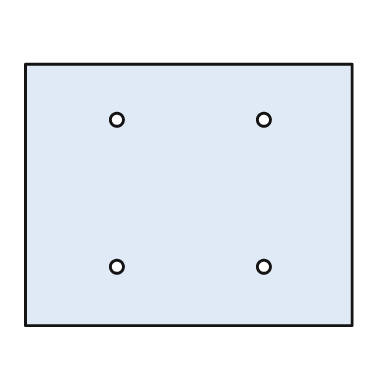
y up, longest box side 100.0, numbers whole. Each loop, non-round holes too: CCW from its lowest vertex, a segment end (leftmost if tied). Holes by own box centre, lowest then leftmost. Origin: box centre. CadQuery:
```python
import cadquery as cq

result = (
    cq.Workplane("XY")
    .moveTo(-50.0, -40.0)
    .lineTo(50.0, -40.0)
    .lineTo(50.0, 40.0)
    .lineTo(-50.0, 40.0)
    .close()
    .moveTo(-22.0, -22.0)
    .circle(2.0)
    .moveTo(23.0, -22.0)
    .circle(2.0)
    .moveTo(-22.0, 23.0)
    .circle(2.0)
    .moveTo(23.0, 23.0)
    .circle(2.0)
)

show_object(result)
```